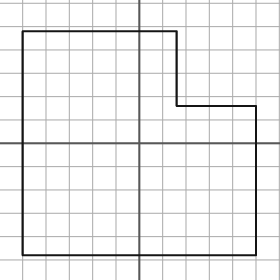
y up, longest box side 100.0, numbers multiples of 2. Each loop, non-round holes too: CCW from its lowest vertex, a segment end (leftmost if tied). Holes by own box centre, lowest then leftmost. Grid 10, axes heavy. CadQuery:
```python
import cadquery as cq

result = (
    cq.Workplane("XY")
    .moveTo(-50.0, -48.0)
    .lineTo(50.0, -48.0)
    .lineTo(50.0, 16.0)
    .lineTo(16.0, 16.0)
    .lineTo(16.0, 48.0)
    .lineTo(-50.0, 48.0)
    .close()
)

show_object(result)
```